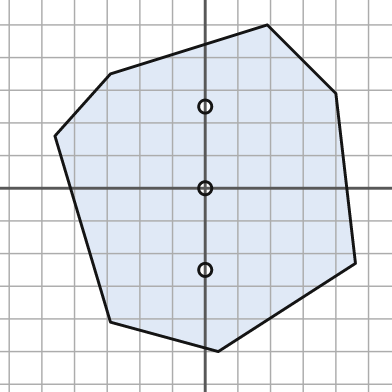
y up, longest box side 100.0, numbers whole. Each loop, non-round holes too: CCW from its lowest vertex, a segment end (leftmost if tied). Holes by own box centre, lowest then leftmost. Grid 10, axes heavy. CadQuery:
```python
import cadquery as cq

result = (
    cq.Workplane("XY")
    .moveTo(4.0, -50.0)
    .lineTo(46.0, -23.0)
    .lineTo(40.0, 29.0)
    .lineTo(19.0, 50.0)
    .lineTo(-29.0, 35.0)
    .lineTo(-46.0, 16.0)
    .lineTo(-29.0, -41.0)
    .close()
    .moveTo(0.0, -25.0)
    .circle(2.0)
    .moveTo(0.0, 0.0)
    .circle(2.0)
    .moveTo(0.0, 25.0)
    .circle(2.0)
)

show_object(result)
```